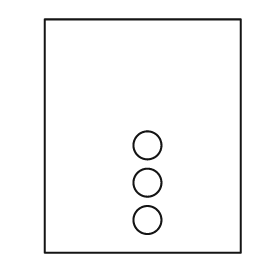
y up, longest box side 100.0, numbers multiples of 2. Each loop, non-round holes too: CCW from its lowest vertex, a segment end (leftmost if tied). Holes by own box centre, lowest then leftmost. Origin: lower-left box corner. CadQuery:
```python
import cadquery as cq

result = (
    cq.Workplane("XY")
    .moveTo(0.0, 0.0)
    .lineTo(84.0, 0.0)
    .lineTo(84.0, 100.0)
    .lineTo(0.0, 100.0)
    .close()
    .moveTo(44.0, 14.0)
    .circle(6.0)
    .moveTo(44.0, 30.0)
    .circle(6.0)
    .moveTo(44.0, 46.0)
    .circle(6.0)
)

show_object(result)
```